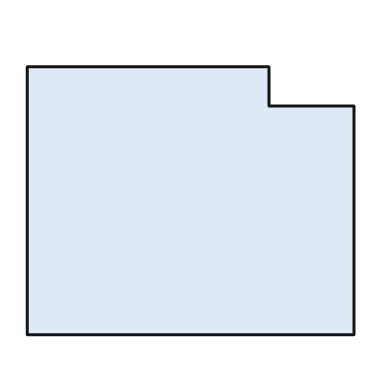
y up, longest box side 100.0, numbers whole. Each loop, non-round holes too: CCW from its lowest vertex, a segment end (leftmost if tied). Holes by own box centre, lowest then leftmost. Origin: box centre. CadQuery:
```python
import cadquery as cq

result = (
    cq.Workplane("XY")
    .moveTo(-50.0, -41.0)
    .lineTo(50.0, -41.0)
    .lineTo(50.0, 29.0)
    .lineTo(24.0, 29.0)
    .lineTo(24.0, 41.0)
    .lineTo(-50.0, 41.0)
    .close()
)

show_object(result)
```